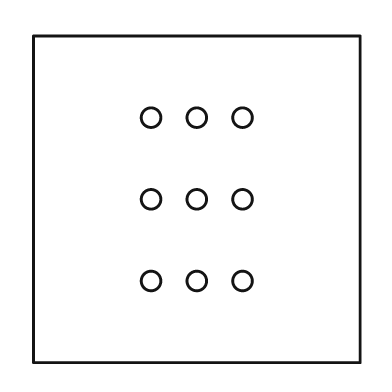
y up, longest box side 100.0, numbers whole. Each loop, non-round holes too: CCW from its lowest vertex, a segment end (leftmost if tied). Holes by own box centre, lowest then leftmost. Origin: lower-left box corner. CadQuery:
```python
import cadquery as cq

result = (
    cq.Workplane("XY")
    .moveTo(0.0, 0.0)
    .lineTo(100.0, 0.0)
    .lineTo(100.0, 100.0)
    .lineTo(0.0, 100.0)
    .close()
    .moveTo(36.0, 25.0)
    .circle(3.0)
    .moveTo(50.0, 25.0)
    .circle(3.0)
    .moveTo(64.0, 25.0)
    .circle(3.0)
    .moveTo(36.0, 50.0)
    .circle(3.0)
    .moveTo(50.0, 50.0)
    .circle(3.0)
    .moveTo(64.0, 50.0)
    .circle(3.0)
    .moveTo(36.0, 75.0)
    .circle(3.0)
    .moveTo(50.0, 75.0)
    .circle(3.0)
    .moveTo(64.0, 75.0)
    .circle(3.0)
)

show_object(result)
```